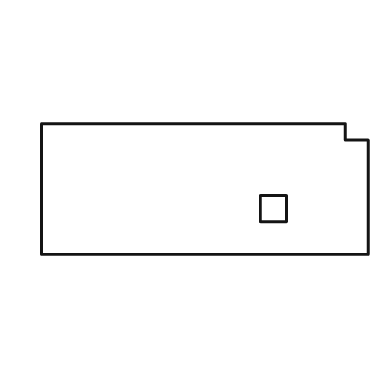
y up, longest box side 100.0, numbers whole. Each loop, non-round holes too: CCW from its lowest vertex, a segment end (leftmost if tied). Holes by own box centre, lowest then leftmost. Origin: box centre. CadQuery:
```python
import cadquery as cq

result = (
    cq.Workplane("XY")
    .moveTo(-50.0, -20.0)
    .lineTo(50.0, -20.0)
    .lineTo(50.0, 15.0)
    .lineTo(43.0, 15.0)
    .lineTo(43.0, 20.0)
    .lineTo(-50.0, 20.0)
    .close()
    .moveTo(17.0, -10.0)
    .lineTo(25.0, -10.0)
    .lineTo(25.0, -2.0)
    .lineTo(17.0, -2.0)
    .close()
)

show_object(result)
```